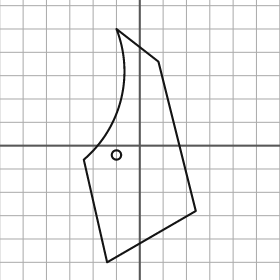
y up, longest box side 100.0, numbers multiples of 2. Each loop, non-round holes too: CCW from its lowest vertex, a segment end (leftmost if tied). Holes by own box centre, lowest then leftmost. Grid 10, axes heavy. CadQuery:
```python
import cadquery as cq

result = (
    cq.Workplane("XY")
    .moveTo(-14.0, -50.0)
    .lineTo(24.0, -28.0)
    .lineTo(8.0, 36.0)
    .lineTo(-10.0, 50.0)
    .threePointArc((-8.0, 20.0), (-24.0, -6.0))
    .close()
    .moveTo(-10.0, -4.0)
    .circle(2.0)
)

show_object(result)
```